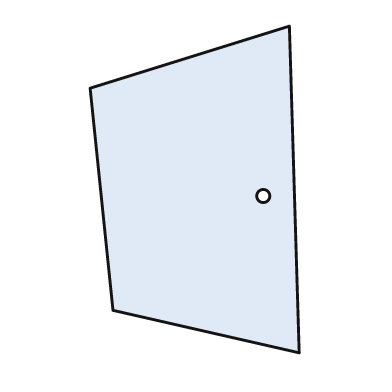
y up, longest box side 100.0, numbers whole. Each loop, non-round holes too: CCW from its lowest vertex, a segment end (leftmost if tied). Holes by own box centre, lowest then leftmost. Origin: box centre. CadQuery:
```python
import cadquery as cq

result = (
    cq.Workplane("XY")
    .moveTo(32.0, -50.0)
    .lineTo(29.0, 50.0)
    .lineTo(-32.0, 31.0)
    .lineTo(-25.0, -37.0)
    .close()
    .moveTo(21.0, -2.0)
    .circle(2.0)
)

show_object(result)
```